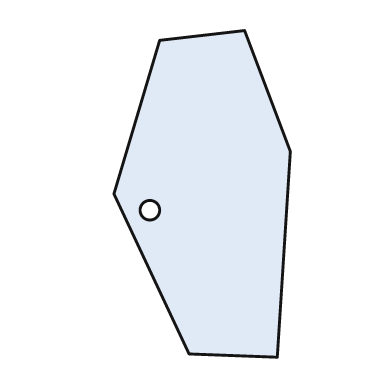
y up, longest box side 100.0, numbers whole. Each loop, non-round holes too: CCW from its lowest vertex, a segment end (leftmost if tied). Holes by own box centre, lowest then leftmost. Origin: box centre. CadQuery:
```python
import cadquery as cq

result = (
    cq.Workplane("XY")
    .moveTo(23.0, -50.0)
    .lineTo(27.0, 13.0)
    .lineTo(13.0, 50.0)
    .lineTo(-13.0, 47.0)
    .lineTo(-27.0, 0.0)
    .lineTo(-4.0, -49.0)
    .close()
    .moveTo(-16.0, -5.0)
    .circle(3.0)
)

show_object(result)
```